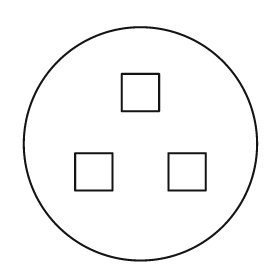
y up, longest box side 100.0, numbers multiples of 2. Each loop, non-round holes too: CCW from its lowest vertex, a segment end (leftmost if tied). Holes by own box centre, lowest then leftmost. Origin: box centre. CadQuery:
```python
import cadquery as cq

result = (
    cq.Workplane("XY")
    .moveTo(0.0, 0.0)
    .circle(50.0)
    .moveTo(-28.0, -20.0)
    .lineTo(-12.0, -20.0)
    .lineTo(-12.0, -4.0)
    .lineTo(-28.0, -4.0)
    .close()
    .moveTo(12.0, -20.0)
    .lineTo(28.0, -20.0)
    .lineTo(28.0, -4.0)
    .lineTo(12.0, -4.0)
    .close()
    .moveTo(-8.0, 14.0)
    .lineTo(8.0, 14.0)
    .lineTo(8.0, 30.0)
    .lineTo(-8.0, 30.0)
    .close()
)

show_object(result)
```